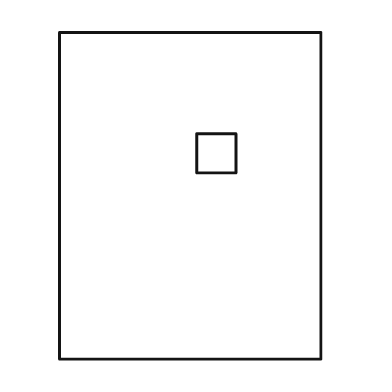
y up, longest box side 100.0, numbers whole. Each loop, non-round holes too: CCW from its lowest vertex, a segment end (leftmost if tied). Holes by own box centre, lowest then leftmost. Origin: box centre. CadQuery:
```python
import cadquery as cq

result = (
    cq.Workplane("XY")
    .moveTo(-40.0, -50.0)
    .lineTo(40.0, -50.0)
    .lineTo(40.0, 50.0)
    .lineTo(-40.0, 50.0)
    .close()
    .moveTo(2.0, 7.0)
    .lineTo(14.0, 7.0)
    .lineTo(14.0, 19.0)
    .lineTo(2.0, 19.0)
    .close()
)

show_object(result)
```